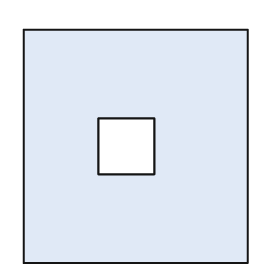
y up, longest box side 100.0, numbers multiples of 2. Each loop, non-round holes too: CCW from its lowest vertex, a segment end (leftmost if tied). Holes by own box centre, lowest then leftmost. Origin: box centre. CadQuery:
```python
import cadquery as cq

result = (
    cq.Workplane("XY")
    .moveTo(-48.0, -50.0)
    .lineTo(48.0, -50.0)
    .lineTo(48.0, 50.0)
    .lineTo(-48.0, 50.0)
    .close()
    .moveTo(-16.0, -12.0)
    .lineTo(8.0, -12.0)
    .lineTo(8.0, 12.0)
    .lineTo(-16.0, 12.0)
    .close()
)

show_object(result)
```